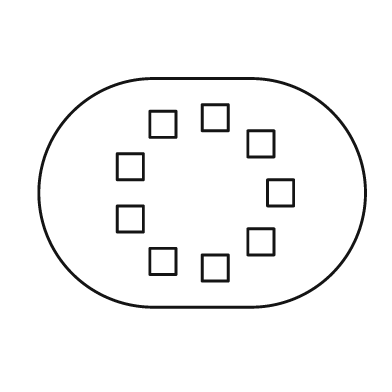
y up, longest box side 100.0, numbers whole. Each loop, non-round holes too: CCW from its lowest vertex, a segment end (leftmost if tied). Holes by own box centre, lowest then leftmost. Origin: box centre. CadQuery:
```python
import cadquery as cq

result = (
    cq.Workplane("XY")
    .moveTo(-15.0, -35.0)
    .lineTo(15.0, -35.0)
    .threePointArc((50.0, 0.0), (15.0, 35.0))
    .lineTo(-15.0, 35.0)
    .threePointArc((-50.0, 0.0), (-15.0, -35.0))
    .close()
    .moveTo(0.0, -27.0)
    .lineTo(8.0, -27.0)
    .lineTo(8.0, -19.0)
    .lineTo(0.0, -19.0)
    .close()
    .moveTo(-16.0, -25.0)
    .lineTo(-8.0, -25.0)
    .lineTo(-8.0, -17.0)
    .lineTo(-16.0, -17.0)
    .close()
    .moveTo(14.0, -19.0)
    .lineTo(22.0, -19.0)
    .lineTo(22.0, -11.0)
    .lineTo(14.0, -11.0)
    .close()
    .moveTo(-26.0, -12.0)
    .lineTo(-18.0, -12.0)
    .lineTo(-18.0, -4.0)
    .lineTo(-26.0, -4.0)
    .close()
    .moveTo(20.0, -4.0)
    .lineTo(28.0, -4.0)
    .lineTo(28.0, 4.0)
    .lineTo(20.0, 4.0)
    .close()
    .moveTo(-26.0, 4.0)
    .lineTo(-18.0, 4.0)
    .lineTo(-18.0, 12.0)
    .lineTo(-26.0, 12.0)
    .close()
    .moveTo(14.0, 11.0)
    .lineTo(22.0, 11.0)
    .lineTo(22.0, 19.0)
    .lineTo(14.0, 19.0)
    .close()
    .moveTo(-16.0, 17.0)
    .lineTo(-8.0, 17.0)
    .lineTo(-8.0, 25.0)
    .lineTo(-16.0, 25.0)
    .close()
    .moveTo(0.0, 19.0)
    .lineTo(8.0, 19.0)
    .lineTo(8.0, 27.0)
    .lineTo(0.0, 27.0)
    .close()
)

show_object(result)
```